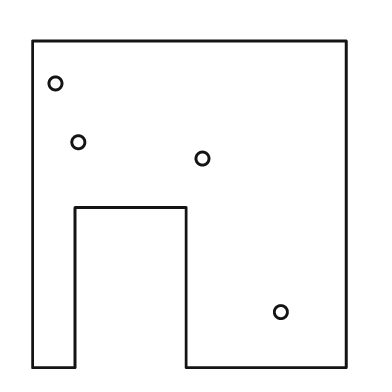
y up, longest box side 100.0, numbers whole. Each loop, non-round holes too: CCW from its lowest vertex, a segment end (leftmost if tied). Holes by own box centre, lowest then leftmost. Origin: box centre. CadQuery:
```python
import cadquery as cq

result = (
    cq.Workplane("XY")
    .moveTo(-48.0, -50.0)
    .lineTo(-35.0, -50.0)
    .lineTo(-35.0, -1.0)
    .lineTo(-1.0, -1.0)
    .lineTo(-1.0, -50.0)
    .lineTo(48.0, -50.0)
    .lineTo(48.0, 50.0)
    .lineTo(-48.0, 50.0)
    .close()
    .moveTo(28.0, -33.0)
    .circle(2.0)
    .moveTo(4.0, 14.0)
    .circle(2.0)
    .moveTo(-34.0, 19.0)
    .circle(2.0)
    .moveTo(-41.0, 37.0)
    .circle(2.0)
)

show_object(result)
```